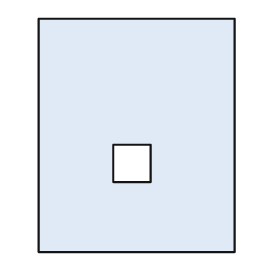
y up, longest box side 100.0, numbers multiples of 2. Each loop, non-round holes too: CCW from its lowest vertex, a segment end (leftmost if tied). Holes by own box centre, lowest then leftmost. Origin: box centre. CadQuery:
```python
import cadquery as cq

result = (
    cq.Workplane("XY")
    .moveTo(-42.0, -50.0)
    .lineTo(42.0, -50.0)
    .lineTo(42.0, 50.0)
    .lineTo(-42.0, 50.0)
    .close()
    .moveTo(-10.0, -20.0)
    .lineTo(6.0, -20.0)
    .lineTo(6.0, -4.0)
    .lineTo(-10.0, -4.0)
    .close()
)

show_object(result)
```